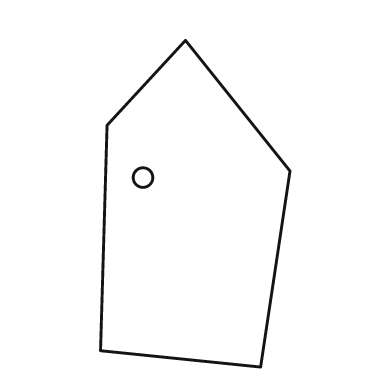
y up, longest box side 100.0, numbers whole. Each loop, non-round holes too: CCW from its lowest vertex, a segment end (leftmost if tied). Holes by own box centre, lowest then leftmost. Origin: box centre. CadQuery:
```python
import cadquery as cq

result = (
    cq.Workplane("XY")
    .moveTo(20.0, -50.0)
    .lineTo(29.0, 10.0)
    .lineTo(-3.0, 50.0)
    .lineTo(-27.0, 24.0)
    .lineTo(-29.0, -45.0)
    .close()
    .moveTo(-16.0, 8.0)
    .circle(3.0)
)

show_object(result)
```